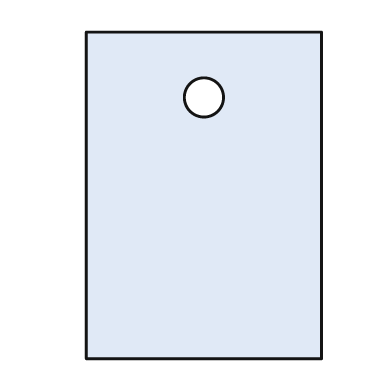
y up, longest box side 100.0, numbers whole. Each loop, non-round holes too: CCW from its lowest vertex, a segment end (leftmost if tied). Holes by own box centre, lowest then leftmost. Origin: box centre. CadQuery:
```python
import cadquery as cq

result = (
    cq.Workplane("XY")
    .moveTo(-36.0, -50.0)
    .lineTo(36.0, -50.0)
    .lineTo(36.0, 50.0)
    .lineTo(-36.0, 50.0)
    .close()
    .moveTo(0.0, 30.0)
    .circle(6.0)
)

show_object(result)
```